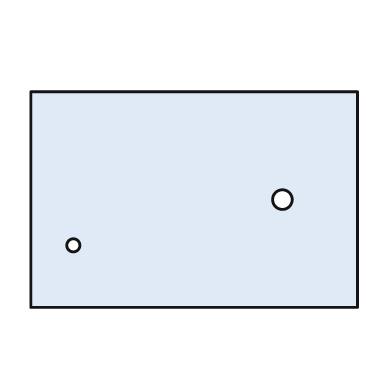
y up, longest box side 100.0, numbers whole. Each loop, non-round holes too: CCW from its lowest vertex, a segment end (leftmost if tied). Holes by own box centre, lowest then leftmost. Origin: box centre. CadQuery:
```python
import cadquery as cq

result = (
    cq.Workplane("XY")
    .moveTo(-50.0, -33.0)
    .lineTo(50.0, -33.0)
    .lineTo(50.0, 33.0)
    .lineTo(-50.0, 33.0)
    .close()
    .moveTo(-37.0, -14.0)
    .circle(2.0)
    .moveTo(27.0, 0.0)
    .circle(3.0)
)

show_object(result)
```